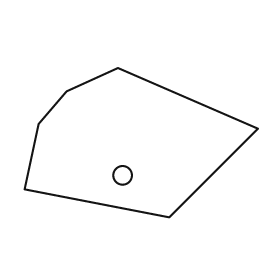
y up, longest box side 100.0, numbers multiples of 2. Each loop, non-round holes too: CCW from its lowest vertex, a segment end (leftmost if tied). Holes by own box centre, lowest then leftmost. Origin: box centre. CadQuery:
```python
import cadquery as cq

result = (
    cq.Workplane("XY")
    .moveTo(12.0, -32.0)
    .lineTo(50.0, 6.0)
    .lineTo(-10.0, 32.0)
    .lineTo(-32.0, 22.0)
    .lineTo(-44.0, 8.0)
    .lineTo(-50.0, -20.0)
    .close()
    .moveTo(-8.0, -14.0)
    .circle(4.0)
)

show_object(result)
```